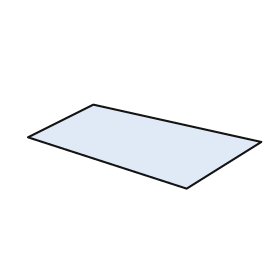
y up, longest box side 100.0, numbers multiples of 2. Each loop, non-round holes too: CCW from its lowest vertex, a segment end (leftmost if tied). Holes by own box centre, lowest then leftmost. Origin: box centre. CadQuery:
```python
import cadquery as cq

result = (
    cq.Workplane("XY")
    .moveTo(18.0, -18.0)
    .lineTo(50.0, 2.0)
    .lineTo(-22.0, 18.0)
    .lineTo(-50.0, 4.0)
    .close()
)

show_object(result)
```